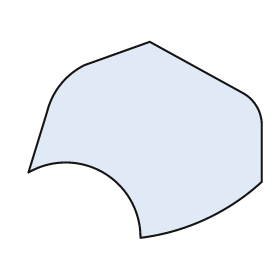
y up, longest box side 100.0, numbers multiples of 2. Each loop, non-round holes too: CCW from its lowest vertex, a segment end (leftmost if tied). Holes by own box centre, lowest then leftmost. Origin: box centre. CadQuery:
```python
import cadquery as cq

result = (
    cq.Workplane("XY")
    .moveTo(-2.0, -42.0)
    .threePointArc((26.0, -34.0), (50.0, -18.0))
    .lineTo(50.0, 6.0)
    .threePointArc((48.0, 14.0), (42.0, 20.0))
    .lineTo(2.0, 42.0)
    .lineTo(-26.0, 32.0)
    .threePointArc((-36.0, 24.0), (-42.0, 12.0))
    .lineTo(-50.0, -14.0)
    .threePointArc((-18.0, -14.0), (-2.0, -42.0))
    .close()
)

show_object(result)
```